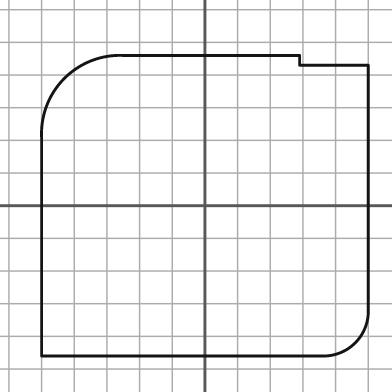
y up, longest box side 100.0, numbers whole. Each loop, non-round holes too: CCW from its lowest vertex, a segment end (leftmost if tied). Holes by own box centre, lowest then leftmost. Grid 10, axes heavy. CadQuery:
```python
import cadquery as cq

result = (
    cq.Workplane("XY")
    .moveTo(-50.0, -46.0)
    .lineTo(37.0, -46.0)
    .threePointArc((46.0, -42.0), (50.0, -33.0))
    .lineTo(50.0, 43.0)
    .lineTo(29.0, 43.0)
    .lineTo(29.0, 46.0)
    .lineTo(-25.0, 46.0)
    .threePointArc((-43.0, 39.0), (-50.0, 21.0))
    .close()
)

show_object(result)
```